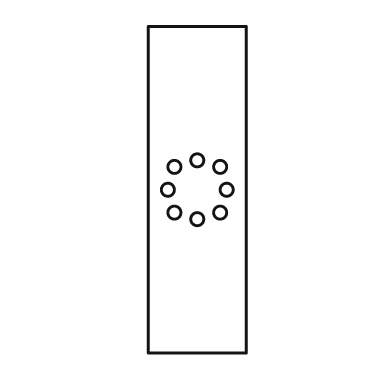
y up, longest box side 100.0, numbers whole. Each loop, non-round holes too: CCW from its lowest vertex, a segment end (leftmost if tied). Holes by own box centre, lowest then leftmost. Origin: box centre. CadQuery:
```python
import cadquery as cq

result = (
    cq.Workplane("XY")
    .moveTo(-15.0, -50.0)
    .lineTo(15.0, -50.0)
    .lineTo(15.0, 50.0)
    .lineTo(-15.0, 50.0)
    .close()
    .moveTo(0.0, -9.0)
    .circle(2.0)
    .moveTo(-7.0, -7.0)
    .circle(2.0)
    .moveTo(7.0, -7.0)
    .circle(2.0)
    .moveTo(-9.0, 0.0)
    .circle(2.0)
    .moveTo(9.0, 0.0)
    .circle(2.0)
    .moveTo(-7.0, 7.0)
    .circle(2.0)
    .moveTo(7.0, 7.0)
    .circle(2.0)
    .moveTo(0.0, 9.0)
    .circle(2.0)
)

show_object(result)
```